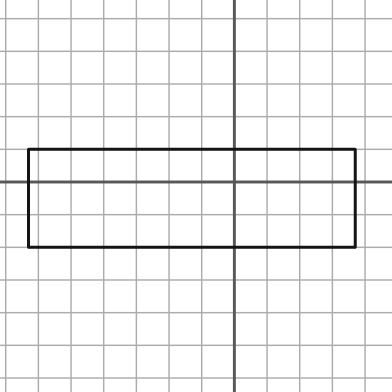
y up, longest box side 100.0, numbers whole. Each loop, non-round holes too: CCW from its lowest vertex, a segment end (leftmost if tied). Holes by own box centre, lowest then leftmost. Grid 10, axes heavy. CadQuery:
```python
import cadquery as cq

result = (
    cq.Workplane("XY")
    .moveTo(-63.0, -20.0)
    .lineTo(37.0, -20.0)
    .lineTo(37.0, 10.0)
    .lineTo(-63.0, 10.0)
    .close()
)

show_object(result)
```